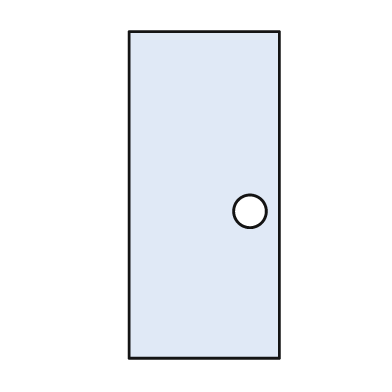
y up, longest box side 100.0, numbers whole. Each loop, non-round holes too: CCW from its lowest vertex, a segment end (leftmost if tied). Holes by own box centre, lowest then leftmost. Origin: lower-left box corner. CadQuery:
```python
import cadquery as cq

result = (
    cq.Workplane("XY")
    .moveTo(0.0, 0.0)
    .lineTo(46.0, 0.0)
    .lineTo(46.0, 100.0)
    .lineTo(0.0, 100.0)
    .close()
    .moveTo(37.0, 45.0)
    .circle(5.0)
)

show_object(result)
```